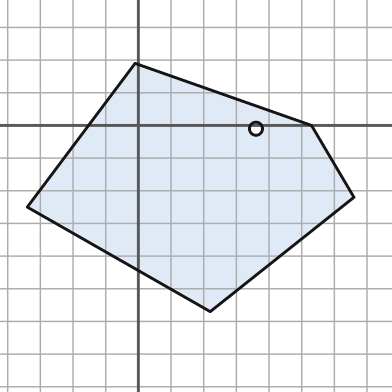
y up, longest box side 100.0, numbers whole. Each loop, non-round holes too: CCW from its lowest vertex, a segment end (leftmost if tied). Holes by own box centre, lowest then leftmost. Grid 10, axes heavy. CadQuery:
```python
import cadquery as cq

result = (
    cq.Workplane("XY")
    .moveTo(22.0, -57.0)
    .lineTo(66.0, -22.0)
    .lineTo(53.0, 0.0)
    .lineTo(-1.0, 19.0)
    .lineTo(-34.0, -25.0)
    .close()
    .moveTo(36.0, -1.0)
    .circle(2.0)
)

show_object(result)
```